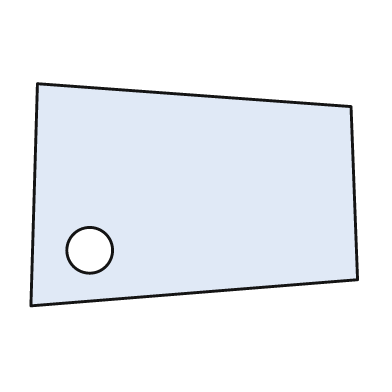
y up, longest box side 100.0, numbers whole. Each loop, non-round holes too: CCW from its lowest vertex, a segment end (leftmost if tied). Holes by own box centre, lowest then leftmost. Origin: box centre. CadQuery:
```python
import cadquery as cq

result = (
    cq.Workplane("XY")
    .moveTo(-50.0, -34.0)
    .lineTo(50.0, -26.0)
    .lineTo(48.0, 27.0)
    .lineTo(-48.0, 34.0)
    .close()
    .moveTo(-32.0, -17.0)
    .circle(7.0)
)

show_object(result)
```